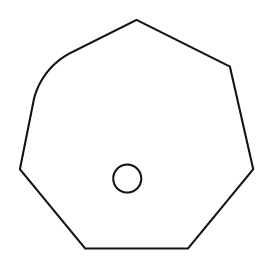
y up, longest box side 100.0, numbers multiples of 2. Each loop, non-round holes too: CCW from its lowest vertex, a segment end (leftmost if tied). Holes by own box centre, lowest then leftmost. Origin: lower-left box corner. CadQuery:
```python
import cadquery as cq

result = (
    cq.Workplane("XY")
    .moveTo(28.0, 0.0)
    .lineTo(72.0, 0.0)
    .lineTo(100.0, 34.0)
    .lineTo(90.0, 78.0)
    .lineTo(50.0, 98.0)
    .lineTo(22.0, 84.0)
    .threePointArc((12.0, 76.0), (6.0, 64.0))
    .lineTo(0.0, 34.0)
    .close()
    .moveTo(46.0, 30.0)
    .circle(6.0)
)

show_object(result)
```